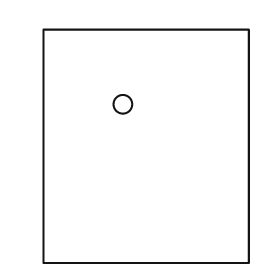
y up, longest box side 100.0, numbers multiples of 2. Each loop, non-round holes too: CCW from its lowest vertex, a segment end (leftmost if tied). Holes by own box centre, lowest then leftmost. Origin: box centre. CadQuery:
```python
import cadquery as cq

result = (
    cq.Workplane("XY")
    .moveTo(-44.0, -50.0)
    .lineTo(44.0, -50.0)
    .lineTo(44.0, 50.0)
    .lineTo(-44.0, 50.0)
    .close()
    .moveTo(-10.0, 18.0)
    .circle(4.0)
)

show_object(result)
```